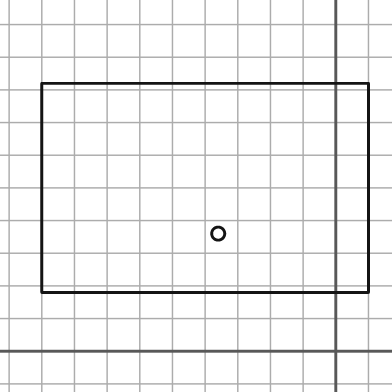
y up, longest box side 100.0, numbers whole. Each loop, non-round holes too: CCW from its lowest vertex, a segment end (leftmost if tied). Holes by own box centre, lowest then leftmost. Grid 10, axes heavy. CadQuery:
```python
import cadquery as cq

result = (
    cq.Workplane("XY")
    .moveTo(-90.0, 18.0)
    .lineTo(10.0, 18.0)
    .lineTo(10.0, 82.0)
    .lineTo(-90.0, 82.0)
    .close()
    .moveTo(-36.0, 36.0)
    .circle(2.0)
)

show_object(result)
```